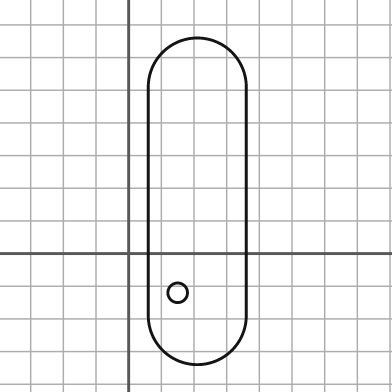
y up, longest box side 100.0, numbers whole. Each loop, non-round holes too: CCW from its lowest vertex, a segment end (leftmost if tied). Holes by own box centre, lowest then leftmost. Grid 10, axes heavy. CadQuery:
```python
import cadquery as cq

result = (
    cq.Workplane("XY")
    .moveTo(6.0, -19.0)
    .threePointArc((21.0, -34.0), (36.0, -19.0))
    .lineTo(36.0, 51.0)
    .threePointArc((21.0, 66.0), (6.0, 51.0))
    .close()
    .moveTo(15.0, -12.0)
    .circle(3.0)
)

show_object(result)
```